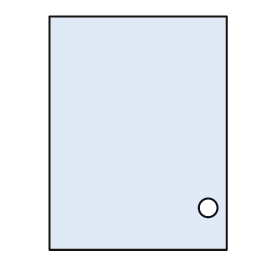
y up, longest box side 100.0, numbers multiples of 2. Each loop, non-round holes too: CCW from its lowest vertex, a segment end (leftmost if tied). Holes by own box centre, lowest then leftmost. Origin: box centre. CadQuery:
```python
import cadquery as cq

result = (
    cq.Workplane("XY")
    .moveTo(-38.0, -50.0)
    .lineTo(38.0, -50.0)
    .lineTo(38.0, 50.0)
    .lineTo(-38.0, 50.0)
    .close()
    .moveTo(30.0, -32.0)
    .circle(4.0)
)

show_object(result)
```